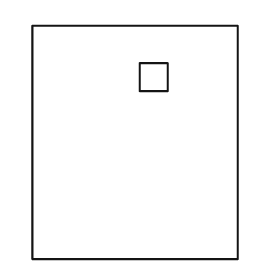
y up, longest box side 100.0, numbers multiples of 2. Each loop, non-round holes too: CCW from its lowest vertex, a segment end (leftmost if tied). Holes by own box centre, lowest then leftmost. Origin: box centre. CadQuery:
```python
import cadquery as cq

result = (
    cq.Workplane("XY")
    .moveTo(-44.0, -50.0)
    .lineTo(44.0, -50.0)
    .lineTo(44.0, 50.0)
    .lineTo(-44.0, 50.0)
    .close()
    .moveTo(2.0, 22.0)
    .lineTo(14.0, 22.0)
    .lineTo(14.0, 34.0)
    .lineTo(2.0, 34.0)
    .close()
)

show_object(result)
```